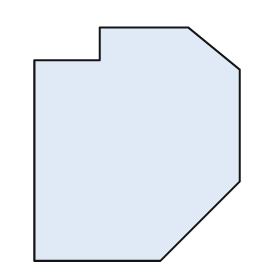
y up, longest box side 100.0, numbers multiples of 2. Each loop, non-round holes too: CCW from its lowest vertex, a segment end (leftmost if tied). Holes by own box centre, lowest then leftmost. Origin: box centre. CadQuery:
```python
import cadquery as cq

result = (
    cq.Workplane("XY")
    .moveTo(-44.0, -50.0)
    .lineTo(10.0, -50.0)
    .lineTo(44.0, -16.0)
    .lineTo(44.0, 32.0)
    .lineTo(22.0, 50.0)
    .lineTo(-16.0, 50.0)
    .lineTo(-16.0, 36.0)
    .lineTo(-44.0, 36.0)
    .close()
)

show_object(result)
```